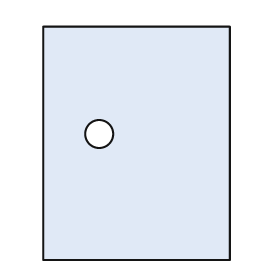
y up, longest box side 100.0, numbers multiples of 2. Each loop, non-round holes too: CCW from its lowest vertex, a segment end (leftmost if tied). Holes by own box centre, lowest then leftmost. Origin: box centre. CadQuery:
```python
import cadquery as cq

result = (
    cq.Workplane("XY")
    .moveTo(-40.0, -50.0)
    .lineTo(40.0, -50.0)
    .lineTo(40.0, 50.0)
    .lineTo(-40.0, 50.0)
    .close()
    .moveTo(-16.0, 4.0)
    .circle(6.0)
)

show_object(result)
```